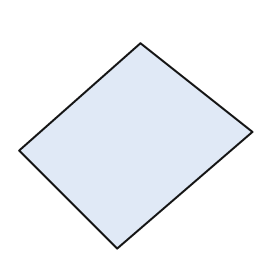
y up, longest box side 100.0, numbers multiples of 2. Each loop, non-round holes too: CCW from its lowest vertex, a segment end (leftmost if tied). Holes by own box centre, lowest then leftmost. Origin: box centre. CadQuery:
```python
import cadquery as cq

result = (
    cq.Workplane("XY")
    .moveTo(-8.0, -44.0)
    .lineTo(50.0, 6.0)
    .lineTo(2.0, 44.0)
    .lineTo(-50.0, -2.0)
    .close()
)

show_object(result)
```